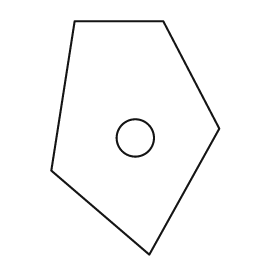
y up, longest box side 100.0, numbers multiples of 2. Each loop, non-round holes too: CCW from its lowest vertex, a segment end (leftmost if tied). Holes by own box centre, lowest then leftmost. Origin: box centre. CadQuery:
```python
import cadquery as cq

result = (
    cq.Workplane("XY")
    .moveTo(6.0, -50.0)
    .lineTo(36.0, 4.0)
    .lineTo(12.0, 50.0)
    .lineTo(-26.0, 50.0)
    .lineTo(-36.0, -14.0)
    .close()
    .moveTo(0.0, 0.0)
    .circle(8.0)
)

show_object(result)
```